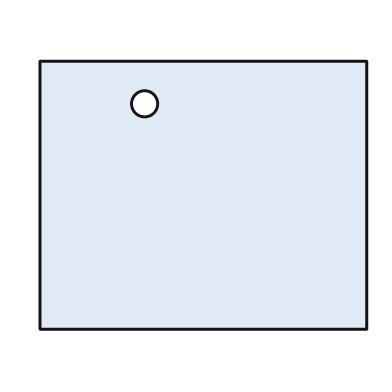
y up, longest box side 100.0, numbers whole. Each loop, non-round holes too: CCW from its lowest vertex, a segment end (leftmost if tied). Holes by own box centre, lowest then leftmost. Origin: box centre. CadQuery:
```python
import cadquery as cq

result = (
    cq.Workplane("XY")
    .moveTo(-50.0, -41.0)
    .lineTo(50.0, -41.0)
    .lineTo(50.0, 41.0)
    .lineTo(-50.0, 41.0)
    .close()
    .moveTo(-18.0, 28.0)
    .circle(4.0)
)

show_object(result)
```